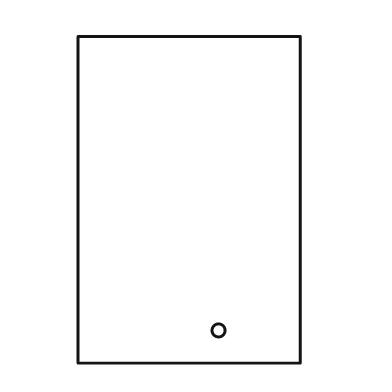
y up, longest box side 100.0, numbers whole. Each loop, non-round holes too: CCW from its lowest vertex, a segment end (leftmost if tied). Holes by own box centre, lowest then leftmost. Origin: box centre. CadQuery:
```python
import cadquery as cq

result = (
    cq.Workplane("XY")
    .moveTo(-34.0, -50.0)
    .lineTo(34.0, -50.0)
    .lineTo(34.0, 50.0)
    .lineTo(-34.0, 50.0)
    .close()
    .moveTo(9.0, -40.0)
    .circle(2.0)
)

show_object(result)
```